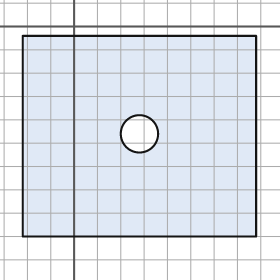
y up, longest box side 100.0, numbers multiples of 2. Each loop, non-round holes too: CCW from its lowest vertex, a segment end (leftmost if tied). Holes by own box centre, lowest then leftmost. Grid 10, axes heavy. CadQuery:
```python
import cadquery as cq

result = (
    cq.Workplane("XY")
    .moveTo(-22.0, -90.0)
    .lineTo(78.0, -90.0)
    .lineTo(78.0, -4.0)
    .lineTo(-22.0, -4.0)
    .close()
    .moveTo(28.0, -46.0)
    .circle(8.0)
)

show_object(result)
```